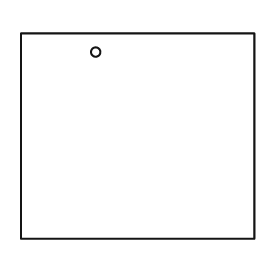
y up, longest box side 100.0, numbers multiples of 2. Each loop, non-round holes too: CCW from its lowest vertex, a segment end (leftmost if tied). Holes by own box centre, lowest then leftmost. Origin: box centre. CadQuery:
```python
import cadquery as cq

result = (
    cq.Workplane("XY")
    .moveTo(-50.0, -44.0)
    .lineTo(50.0, -44.0)
    .lineTo(50.0, 44.0)
    .lineTo(-50.0, 44.0)
    .close()
    .moveTo(-18.0, 36.0)
    .circle(2.0)
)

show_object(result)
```